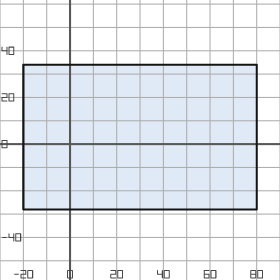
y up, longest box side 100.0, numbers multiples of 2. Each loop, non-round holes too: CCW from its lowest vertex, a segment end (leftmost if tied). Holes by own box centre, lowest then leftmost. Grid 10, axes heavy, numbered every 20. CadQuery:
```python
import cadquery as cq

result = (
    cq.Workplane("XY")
    .moveTo(-20.0, -28.0)
    .lineTo(80.0, -28.0)
    .lineTo(80.0, 34.0)
    .lineTo(-20.0, 34.0)
    .close()
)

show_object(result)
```